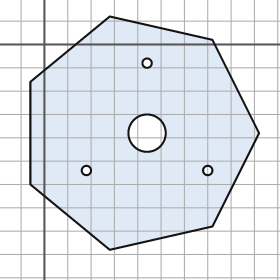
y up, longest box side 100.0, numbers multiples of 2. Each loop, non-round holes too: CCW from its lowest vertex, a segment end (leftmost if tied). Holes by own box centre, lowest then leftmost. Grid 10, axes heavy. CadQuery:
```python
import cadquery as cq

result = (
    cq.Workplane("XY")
    .moveTo(28.0, -88.0)
    .lineTo(72.0, -78.0)
    .lineTo(92.0, -38.0)
    .lineTo(72.0, 2.0)
    .lineTo(28.0, 12.0)
    .lineTo(-6.0, -16.0)
    .lineTo(-6.0, -60.0)
    .close()
    .moveTo(18.0, -54.0)
    .circle(2.0)
    .moveTo(70.0, -54.0)
    .circle(2.0)
    .moveTo(44.0, -38.0)
    .circle(8.0)
    .moveTo(44.0, -8.0)
    .circle(2.0)
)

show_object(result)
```